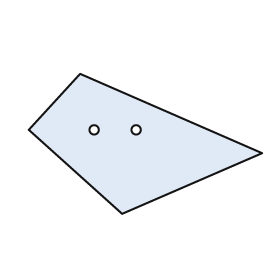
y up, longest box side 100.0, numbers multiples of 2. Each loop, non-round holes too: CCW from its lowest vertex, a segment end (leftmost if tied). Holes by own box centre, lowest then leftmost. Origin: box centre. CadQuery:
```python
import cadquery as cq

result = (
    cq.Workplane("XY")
    .moveTo(-10.0, -30.0)
    .lineTo(50.0, -4.0)
    .lineTo(-28.0, 30.0)
    .lineTo(-50.0, 6.0)
    .close()
    .moveTo(-22.0, 6.0)
    .circle(2.0)
    .moveTo(-4.0, 6.0)
    .circle(2.0)
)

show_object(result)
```